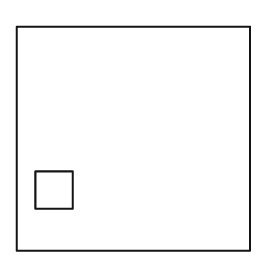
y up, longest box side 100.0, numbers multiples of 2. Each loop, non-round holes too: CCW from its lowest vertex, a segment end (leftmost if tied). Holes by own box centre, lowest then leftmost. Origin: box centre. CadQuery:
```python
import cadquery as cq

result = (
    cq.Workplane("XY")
    .moveTo(-50.0, -48.0)
    .lineTo(50.0, -48.0)
    .lineTo(50.0, 48.0)
    .lineTo(-50.0, 48.0)
    .close()
    .moveTo(-42.0, -30.0)
    .lineTo(-26.0, -30.0)
    .lineTo(-26.0, -14.0)
    .lineTo(-42.0, -14.0)
    .close()
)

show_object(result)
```